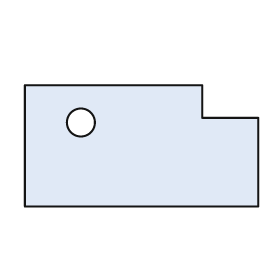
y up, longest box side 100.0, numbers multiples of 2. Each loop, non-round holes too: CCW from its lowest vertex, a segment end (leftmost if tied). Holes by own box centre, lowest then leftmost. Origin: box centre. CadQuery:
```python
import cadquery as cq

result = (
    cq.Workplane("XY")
    .moveTo(-50.0, -26.0)
    .lineTo(50.0, -26.0)
    .lineTo(50.0, 12.0)
    .lineTo(26.0, 12.0)
    .lineTo(26.0, 26.0)
    .lineTo(-50.0, 26.0)
    .close()
    .moveTo(-26.0, 10.0)
    .circle(6.0)
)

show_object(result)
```